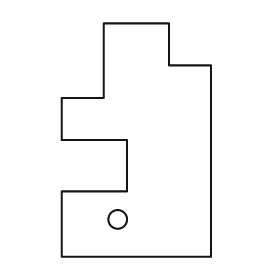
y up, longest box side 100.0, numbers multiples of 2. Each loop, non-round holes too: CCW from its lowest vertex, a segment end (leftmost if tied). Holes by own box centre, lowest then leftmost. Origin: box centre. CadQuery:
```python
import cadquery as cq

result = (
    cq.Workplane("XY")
    .moveTo(-32.0, -50.0)
    .lineTo(32.0, -50.0)
    .lineTo(32.0, 32.0)
    .lineTo(14.0, 32.0)
    .lineTo(14.0, 50.0)
    .lineTo(-14.0, 50.0)
    .lineTo(-14.0, 18.0)
    .lineTo(-32.0, 18.0)
    .lineTo(-32.0, 0.0)
    .lineTo(-4.0, 0.0)
    .lineTo(-4.0, -22.0)
    .lineTo(-32.0, -22.0)
    .close()
    .moveTo(-8.0, -34.0)
    .circle(4.0)
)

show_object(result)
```